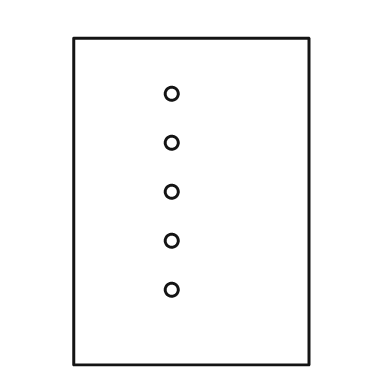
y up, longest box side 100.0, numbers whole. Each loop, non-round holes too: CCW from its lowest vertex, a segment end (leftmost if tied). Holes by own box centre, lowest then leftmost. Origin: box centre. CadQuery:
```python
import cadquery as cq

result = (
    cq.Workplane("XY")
    .moveTo(-36.0, -50.0)
    .lineTo(36.0, -50.0)
    .lineTo(36.0, 50.0)
    .lineTo(-36.0, 50.0)
    .close()
    .moveTo(-6.0, -27.0)
    .circle(2.0)
    .moveTo(-6.0, -12.0)
    .circle(2.0)
    .moveTo(-6.0, 3.0)
    .circle(2.0)
    .moveTo(-6.0, 18.0)
    .circle(2.0)
    .moveTo(-6.0, 33.0)
    .circle(2.0)
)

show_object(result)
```